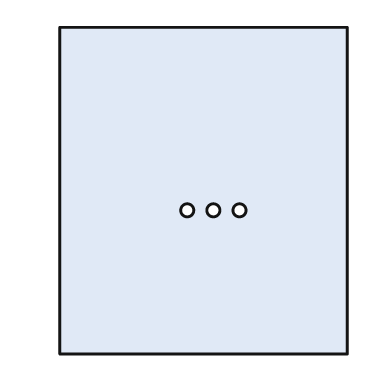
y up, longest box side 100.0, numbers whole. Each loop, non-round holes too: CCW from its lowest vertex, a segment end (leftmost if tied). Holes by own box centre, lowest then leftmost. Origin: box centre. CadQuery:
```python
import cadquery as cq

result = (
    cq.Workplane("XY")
    .moveTo(-44.0, -50.0)
    .lineTo(44.0, -50.0)
    .lineTo(44.0, 50.0)
    .lineTo(-44.0, 50.0)
    .close()
    .moveTo(-5.0, -6.0)
    .circle(2.0)
    .moveTo(3.0, -6.0)
    .circle(2.0)
    .moveTo(11.0, -6.0)
    .circle(2.0)
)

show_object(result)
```